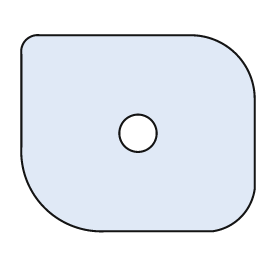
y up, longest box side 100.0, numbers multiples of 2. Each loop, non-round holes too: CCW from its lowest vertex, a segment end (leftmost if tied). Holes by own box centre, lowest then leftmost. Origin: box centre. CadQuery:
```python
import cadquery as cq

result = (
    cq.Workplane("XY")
    .moveTo(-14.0, -42.0)
    .lineTo(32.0, -42.0)
    .threePointArc((44.0, -36.0), (50.0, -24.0))
    .lineTo(50.0, 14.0)
    .threePointArc((42.0, 34.0), (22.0, 42.0))
    .lineTo(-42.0, 42.0)
    .threePointArc((-48.0, 40.0), (-50.0, 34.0))
    .lineTo(-50.0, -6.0)
    .threePointArc((-40.0, -32.0), (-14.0, -42.0))
    .close()
    .moveTo(0.0, 0.0)
    .circle(8.0)
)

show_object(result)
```